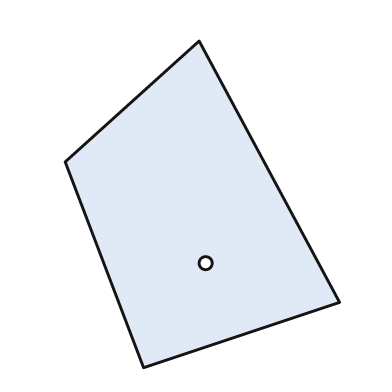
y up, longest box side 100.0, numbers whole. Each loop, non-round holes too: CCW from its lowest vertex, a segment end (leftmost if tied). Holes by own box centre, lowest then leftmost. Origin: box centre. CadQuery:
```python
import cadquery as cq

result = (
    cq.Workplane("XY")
    .moveTo(-18.0, -50.0)
    .lineTo(42.0, -30.0)
    .lineTo(-1.0, 50.0)
    .lineTo(-42.0, 13.0)
    .close()
    .moveTo(1.0, -18.0)
    .circle(2.0)
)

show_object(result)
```